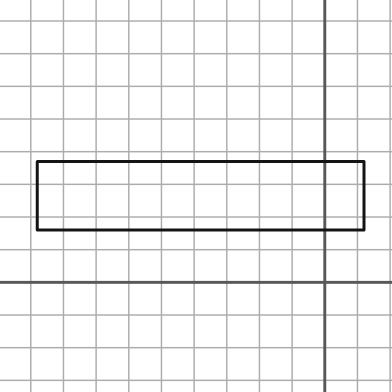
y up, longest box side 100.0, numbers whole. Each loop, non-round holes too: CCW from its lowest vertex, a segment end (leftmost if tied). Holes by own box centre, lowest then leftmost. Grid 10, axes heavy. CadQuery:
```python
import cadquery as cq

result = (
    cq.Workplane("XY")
    .moveTo(-88.0, 16.0)
    .lineTo(12.0, 16.0)
    .lineTo(12.0, 37.0)
    .lineTo(-88.0, 37.0)
    .close()
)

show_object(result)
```